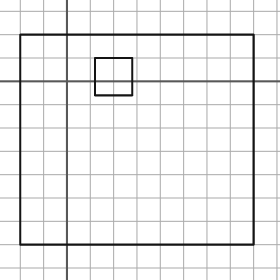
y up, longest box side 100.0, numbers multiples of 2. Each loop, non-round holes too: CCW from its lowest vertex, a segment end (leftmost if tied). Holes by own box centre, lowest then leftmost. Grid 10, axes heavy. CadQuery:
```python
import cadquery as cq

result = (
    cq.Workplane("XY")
    .moveTo(-20.0, -70.0)
    .lineTo(80.0, -70.0)
    .lineTo(80.0, 20.0)
    .lineTo(-20.0, 20.0)
    .close()
    .moveTo(12.0, -6.0)
    .lineTo(28.0, -6.0)
    .lineTo(28.0, 10.0)
    .lineTo(12.0, 10.0)
    .close()
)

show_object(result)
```